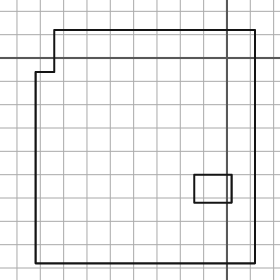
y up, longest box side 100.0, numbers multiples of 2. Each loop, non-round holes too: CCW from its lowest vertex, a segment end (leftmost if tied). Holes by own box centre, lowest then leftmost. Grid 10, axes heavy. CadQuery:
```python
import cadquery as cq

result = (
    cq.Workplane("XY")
    .moveTo(-82.0, -88.0)
    .lineTo(12.0, -88.0)
    .lineTo(12.0, 12.0)
    .lineTo(-74.0, 12.0)
    .lineTo(-74.0, -6.0)
    .lineTo(-82.0, -6.0)
    .close()
    .moveTo(-14.0, -62.0)
    .lineTo(2.0, -62.0)
    .lineTo(2.0, -50.0)
    .lineTo(-14.0, -50.0)
    .close()
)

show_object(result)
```